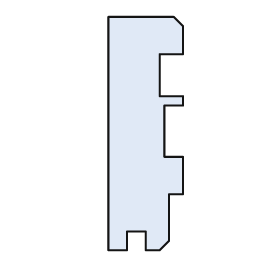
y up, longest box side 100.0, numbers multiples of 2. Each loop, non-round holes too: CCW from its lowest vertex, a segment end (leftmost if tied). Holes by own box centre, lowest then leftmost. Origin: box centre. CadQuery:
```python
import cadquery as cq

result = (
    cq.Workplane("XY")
    .moveTo(-16.0, -50.0)
    .lineTo(-8.0, -50.0)
    .lineTo(-8.0, -42.0)
    .lineTo(0.0, -42.0)
    .lineTo(0.0, -50.0)
    .lineTo(6.0, -50.0)
    .lineTo(10.0, -46.0)
    .lineTo(10.0, -26.0)
    .lineTo(16.0, -26.0)
    .lineTo(16.0, -10.0)
    .lineTo(8.0, -10.0)
    .lineTo(8.0, 12.0)
    .lineTo(16.0, 12.0)
    .lineTo(16.0, 16.0)
    .lineTo(6.0, 16.0)
    .lineTo(6.0, 34.0)
    .lineTo(16.0, 34.0)
    .lineTo(16.0, 46.0)
    .lineTo(12.0, 50.0)
    .lineTo(-16.0, 50.0)
    .close()
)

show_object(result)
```